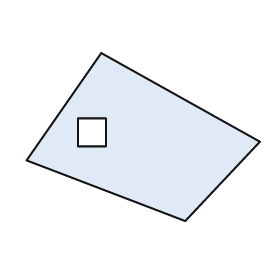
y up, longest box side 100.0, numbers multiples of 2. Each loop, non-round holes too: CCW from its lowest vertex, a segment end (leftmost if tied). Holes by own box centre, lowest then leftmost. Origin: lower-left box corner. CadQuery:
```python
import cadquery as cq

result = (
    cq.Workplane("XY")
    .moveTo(68.0, 0.0)
    .lineTo(100.0, 34.0)
    .lineTo(32.0, 72.0)
    .lineTo(0.0, 26.0)
    .close()
    .moveTo(22.0, 32.0)
    .lineTo(34.0, 32.0)
    .lineTo(34.0, 44.0)
    .lineTo(22.0, 44.0)
    .close()
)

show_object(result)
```